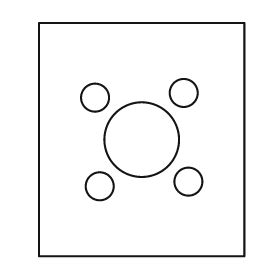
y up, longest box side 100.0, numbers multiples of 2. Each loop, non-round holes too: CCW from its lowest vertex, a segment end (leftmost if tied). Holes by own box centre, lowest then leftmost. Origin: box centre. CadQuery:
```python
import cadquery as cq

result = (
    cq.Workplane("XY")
    .moveTo(-44.0, -50.0)
    .lineTo(44.0, -50.0)
    .lineTo(44.0, 50.0)
    .lineTo(-44.0, 50.0)
    .close()
    .moveTo(-18.0, -20.0)
    .circle(6.0)
    .moveTo(20.0, -18.0)
    .circle(6.0)
    .moveTo(0.0, 0.0)
    .circle(16.0)
    .moveTo(-20.0, 18.0)
    .circle(6.0)
    .moveTo(18.0, 20.0)
    .circle(6.0)
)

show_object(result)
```